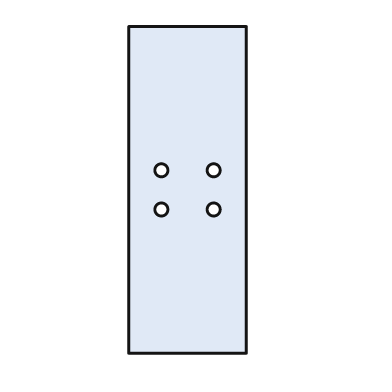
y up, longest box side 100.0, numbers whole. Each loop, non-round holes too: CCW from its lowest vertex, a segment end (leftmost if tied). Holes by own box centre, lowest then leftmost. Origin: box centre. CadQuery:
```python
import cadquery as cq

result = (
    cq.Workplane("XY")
    .moveTo(-18.0, -50.0)
    .lineTo(18.0, -50.0)
    .lineTo(18.0, 50.0)
    .lineTo(-18.0, 50.0)
    .close()
    .moveTo(-8.0, -6.0)
    .circle(2.0)
    .moveTo(8.0, -6.0)
    .circle(2.0)
    .moveTo(-8.0, 6.0)
    .circle(2.0)
    .moveTo(8.0, 6.0)
    .circle(2.0)
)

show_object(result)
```